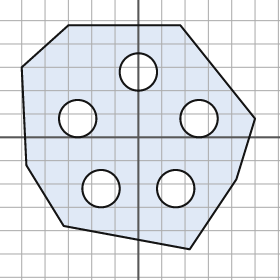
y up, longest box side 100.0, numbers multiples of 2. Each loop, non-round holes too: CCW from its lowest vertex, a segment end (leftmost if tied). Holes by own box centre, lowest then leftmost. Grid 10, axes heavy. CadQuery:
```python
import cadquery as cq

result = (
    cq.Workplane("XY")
    .moveTo(22.0, -48.0)
    .lineTo(42.0, -18.0)
    .lineTo(50.0, 8.0)
    .lineTo(18.0, 48.0)
    .lineTo(-30.0, 48.0)
    .lineTo(-50.0, 30.0)
    .lineTo(-48.0, -12.0)
    .lineTo(-32.0, -38.0)
    .close()
    .moveTo(-16.0, -22.0)
    .circle(8.0)
    .moveTo(16.0, -22.0)
    .circle(8.0)
    .moveTo(-26.0, 8.0)
    .circle(8.0)
    .moveTo(26.0, 8.0)
    .circle(8.0)
    .moveTo(0.0, 28.0)
    .circle(8.0)
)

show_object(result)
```